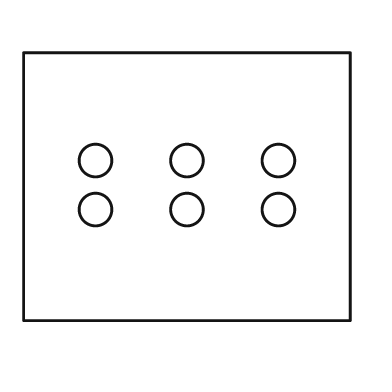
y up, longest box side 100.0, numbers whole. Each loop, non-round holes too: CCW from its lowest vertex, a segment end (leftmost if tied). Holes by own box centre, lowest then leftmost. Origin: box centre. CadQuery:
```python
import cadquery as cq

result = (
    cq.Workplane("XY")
    .moveTo(-50.0, -41.0)
    .lineTo(50.0, -41.0)
    .lineTo(50.0, 41.0)
    .lineTo(-50.0, 41.0)
    .close()
    .moveTo(-28.0, -7.0)
    .circle(5.0)
    .moveTo(0.0, -7.0)
    .circle(5.0)
    .moveTo(28.0, -7.0)
    .circle(5.0)
    .moveTo(-28.0, 8.0)
    .circle(5.0)
    .moveTo(0.0, 8.0)
    .circle(5.0)
    .moveTo(28.0, 8.0)
    .circle(5.0)
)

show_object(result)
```